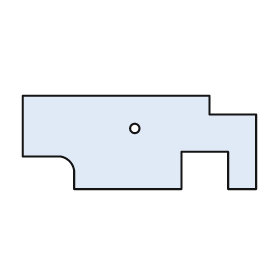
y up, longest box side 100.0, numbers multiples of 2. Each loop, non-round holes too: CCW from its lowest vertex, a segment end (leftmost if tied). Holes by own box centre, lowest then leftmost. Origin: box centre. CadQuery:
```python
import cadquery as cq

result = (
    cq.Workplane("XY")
    .moveTo(-28.0, -20.0)
    .lineTo(18.0, -20.0)
    .lineTo(18.0, -4.0)
    .lineTo(38.0, -4.0)
    .lineTo(38.0, -20.0)
    .lineTo(50.0, -20.0)
    .lineTo(50.0, 12.0)
    .lineTo(30.0, 12.0)
    .lineTo(30.0, 20.0)
    .lineTo(-50.0, 20.0)
    .lineTo(-50.0, -6.0)
    .lineTo(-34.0, -6.0)
    .threePointArc((-30.0, -8.0), (-28.0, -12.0))
    .close()
    .moveTo(-2.0, 6.0)
    .circle(2.0)
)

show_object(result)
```